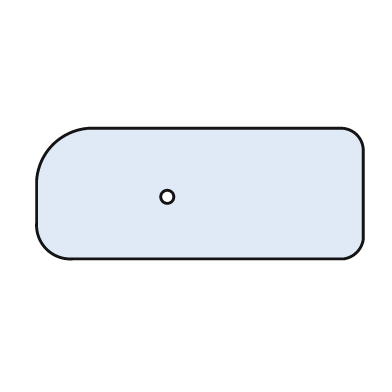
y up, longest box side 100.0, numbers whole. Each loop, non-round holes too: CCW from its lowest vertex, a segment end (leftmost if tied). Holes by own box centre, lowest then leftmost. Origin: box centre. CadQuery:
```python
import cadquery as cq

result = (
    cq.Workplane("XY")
    .moveTo(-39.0, -20.0)
    .lineTo(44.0, -20.0)
    .threePointArc((48.0, -18.0), (50.0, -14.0))
    .lineTo(50.0, 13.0)
    .threePointArc((48.0, 18.0), (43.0, 20.0))
    .lineTo(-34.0, 20.0)
    .threePointArc((-45.0, 15.0), (-50.0, 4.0))
    .lineTo(-50.0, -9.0)
    .threePointArc((-47.0, -17.0), (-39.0, -20.0))
    .close()
    .moveTo(-10.0, -1.0)
    .circle(2.0)
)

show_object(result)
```